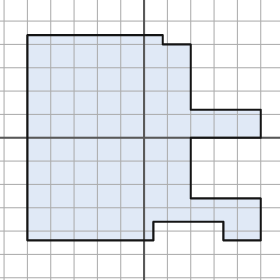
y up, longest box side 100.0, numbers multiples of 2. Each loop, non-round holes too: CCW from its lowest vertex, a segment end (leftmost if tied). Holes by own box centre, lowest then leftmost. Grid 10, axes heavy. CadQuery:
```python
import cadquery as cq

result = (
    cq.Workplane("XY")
    .moveTo(-50.0, -44.0)
    .lineTo(4.0, -44.0)
    .lineTo(4.0, -36.0)
    .lineTo(34.0, -36.0)
    .lineTo(34.0, -44.0)
    .lineTo(50.0, -44.0)
    .lineTo(50.0, -26.0)
    .lineTo(20.0, -26.0)
    .lineTo(20.0, 0.0)
    .lineTo(50.0, 0.0)
    .lineTo(50.0, 12.0)
    .lineTo(20.0, 12.0)
    .lineTo(20.0, 40.0)
    .lineTo(8.0, 40.0)
    .lineTo(8.0, 44.0)
    .lineTo(-50.0, 44.0)
    .close()
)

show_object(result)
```